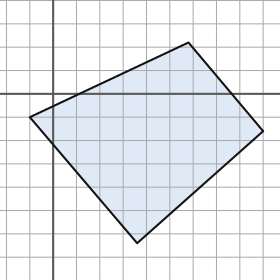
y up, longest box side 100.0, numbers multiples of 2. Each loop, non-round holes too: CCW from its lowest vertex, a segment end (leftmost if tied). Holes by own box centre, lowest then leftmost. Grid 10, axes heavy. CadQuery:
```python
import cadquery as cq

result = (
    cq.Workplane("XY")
    .moveTo(36.0, -64.0)
    .lineTo(90.0, -16.0)
    .lineTo(58.0, 22.0)
    .lineTo(-10.0, -10.0)
    .close()
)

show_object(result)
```